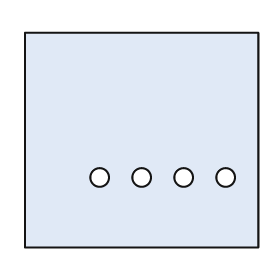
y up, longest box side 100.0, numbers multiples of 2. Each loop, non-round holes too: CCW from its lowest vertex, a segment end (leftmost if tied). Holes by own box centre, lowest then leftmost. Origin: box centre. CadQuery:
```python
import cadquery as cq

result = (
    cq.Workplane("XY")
    .moveTo(-50.0, -46.0)
    .lineTo(50.0, -46.0)
    .lineTo(50.0, 46.0)
    .lineTo(-50.0, 46.0)
    .close()
    .moveTo(-18.0, -16.0)
    .circle(4.0)
    .moveTo(0.0, -16.0)
    .circle(4.0)
    .moveTo(18.0, -16.0)
    .circle(4.0)
    .moveTo(36.0, -16.0)
    .circle(4.0)
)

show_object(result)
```